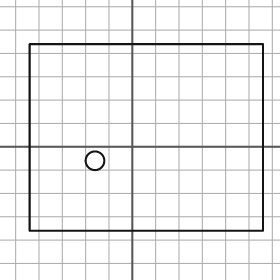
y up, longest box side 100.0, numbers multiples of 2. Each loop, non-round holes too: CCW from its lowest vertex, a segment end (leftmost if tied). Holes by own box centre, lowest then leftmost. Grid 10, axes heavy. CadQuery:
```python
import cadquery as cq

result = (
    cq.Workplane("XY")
    .moveTo(-44.0, -36.0)
    .lineTo(56.0, -36.0)
    .lineTo(56.0, 44.0)
    .lineTo(-44.0, 44.0)
    .close()
    .moveTo(-16.0, -6.0)
    .circle(4.0)
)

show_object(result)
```